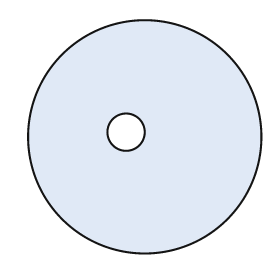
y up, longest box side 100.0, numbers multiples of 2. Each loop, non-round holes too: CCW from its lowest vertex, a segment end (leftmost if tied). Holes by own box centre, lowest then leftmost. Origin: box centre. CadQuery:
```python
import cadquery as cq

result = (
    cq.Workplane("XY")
    .moveTo(0.0, 0.0)
    .circle(50.0)
    .moveTo(-8.0, 2.0)
    .circle(8.0)
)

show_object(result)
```